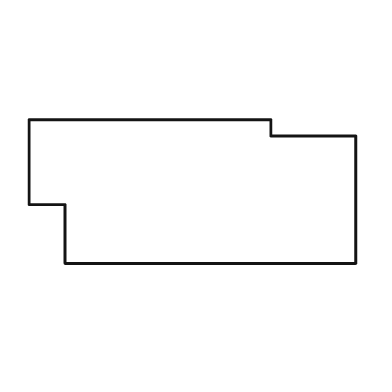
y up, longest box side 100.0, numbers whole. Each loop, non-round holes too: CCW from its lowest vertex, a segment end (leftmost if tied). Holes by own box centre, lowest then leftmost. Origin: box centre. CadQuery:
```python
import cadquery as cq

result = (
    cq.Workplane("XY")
    .moveTo(-39.0, -22.0)
    .lineTo(50.0, -22.0)
    .lineTo(50.0, 17.0)
    .lineTo(24.0, 17.0)
    .lineTo(24.0, 22.0)
    .lineTo(-50.0, 22.0)
    .lineTo(-50.0, -4.0)
    .lineTo(-39.0, -4.0)
    .close()
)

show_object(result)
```